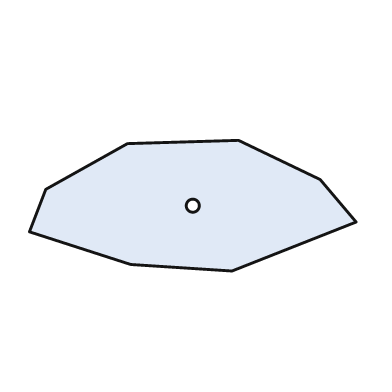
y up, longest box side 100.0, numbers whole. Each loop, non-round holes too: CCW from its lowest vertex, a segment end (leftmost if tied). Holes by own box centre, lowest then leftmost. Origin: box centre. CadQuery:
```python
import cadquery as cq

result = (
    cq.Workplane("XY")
    .moveTo(12.0, -20.0)
    .lineTo(50.0, -5.0)
    .lineTo(39.0, 8.0)
    .lineTo(14.0, 20.0)
    .lineTo(-20.0, 19.0)
    .lineTo(-45.0, 5.0)
    .lineTo(-50.0, -8.0)
    .lineTo(-19.0, -18.0)
    .close()
    .moveTo(0.0, 0.0)
    .circle(2.0)
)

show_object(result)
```